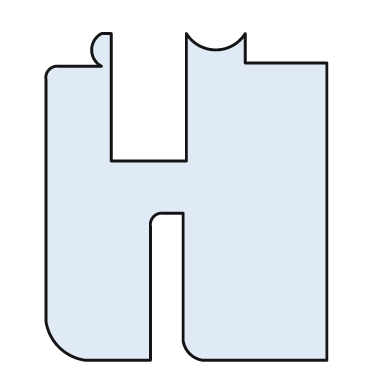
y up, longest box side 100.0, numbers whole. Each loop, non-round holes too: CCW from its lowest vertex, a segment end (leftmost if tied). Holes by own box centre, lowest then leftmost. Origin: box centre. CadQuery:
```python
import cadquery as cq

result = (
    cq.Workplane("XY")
    .moveTo(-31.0, -50.0)
    .lineTo(-11.0, -50.0)
    .lineTo(-11.0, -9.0)
    .threePointArc((-10.0, -6.0), (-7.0, -5.0))
    .lineTo(-1.0, -5.0)
    .lineTo(-1.0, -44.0)
    .threePointArc((1.0, -48.0), (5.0, -50.0))
    .lineTo(43.0, -50.0)
    .lineTo(43.0, 41.0)
    .lineTo(18.0, 41.0)
    .lineTo(18.0, 50.0)
    .threePointArc((9.0, 45.0), (0.0, 50.0))
    .lineTo(0.0, 11.0)
    .lineTo(-23.0, 11.0)
    .lineTo(-23.0, 50.0)
    .lineTo(-26.0, 50.0)
    .threePointArc((-29.0, 45.0), (-26.0, 40.0))
    .lineTo(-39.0, 40.0)
    .threePointArc((-42.0, 39.0), (-43.0, 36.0))
    .lineTo(-43.0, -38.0)
    .threePointArc((-39.0, -46.0), (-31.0, -50.0))
    .close()
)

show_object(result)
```